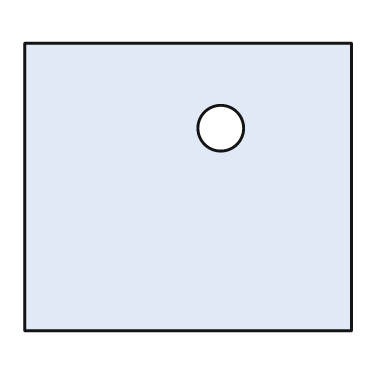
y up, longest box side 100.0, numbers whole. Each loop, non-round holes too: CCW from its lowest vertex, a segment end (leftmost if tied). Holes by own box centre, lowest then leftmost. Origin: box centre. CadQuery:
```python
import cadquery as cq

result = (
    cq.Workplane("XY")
    .moveTo(-50.0, -44.0)
    .lineTo(50.0, -44.0)
    .lineTo(50.0, 44.0)
    .lineTo(-50.0, 44.0)
    .close()
    .moveTo(10.0, 18.0)
    .circle(7.0)
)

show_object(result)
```